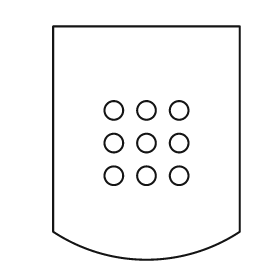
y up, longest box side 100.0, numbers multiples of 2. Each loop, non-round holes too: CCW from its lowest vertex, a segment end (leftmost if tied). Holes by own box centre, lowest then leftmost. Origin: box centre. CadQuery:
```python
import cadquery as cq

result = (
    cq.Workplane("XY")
    .moveTo(-40.0, -38.0)
    .threePointArc((0.0, -50.0), (40.0, -38.0))
    .lineTo(40.0, 50.0)
    .lineTo(-40.0, 50.0)
    .close()
    .moveTo(-14.0, -14.0)
    .circle(4.0)
    .moveTo(0.0, -14.0)
    .circle(4.0)
    .moveTo(14.0, -14.0)
    .circle(4.0)
    .moveTo(-14.0, 0.0)
    .circle(4.0)
    .moveTo(0.0, 0.0)
    .circle(4.0)
    .moveTo(14.0, 0.0)
    .circle(4.0)
    .moveTo(-14.0, 14.0)
    .circle(4.0)
    .moveTo(0.0, 14.0)
    .circle(4.0)
    .moveTo(14.0, 14.0)
    .circle(4.0)
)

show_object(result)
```